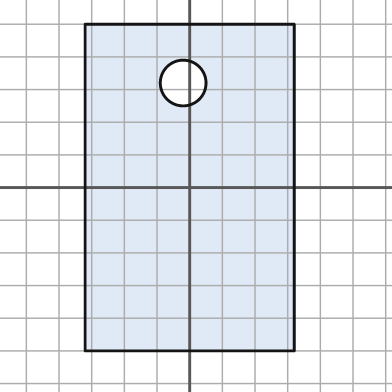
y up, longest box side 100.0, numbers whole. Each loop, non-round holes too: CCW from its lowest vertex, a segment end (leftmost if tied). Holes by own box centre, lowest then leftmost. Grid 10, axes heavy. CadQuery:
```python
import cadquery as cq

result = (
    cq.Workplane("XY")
    .moveTo(-32.0, -50.0)
    .lineTo(32.0, -50.0)
    .lineTo(32.0, 50.0)
    .lineTo(-32.0, 50.0)
    .close()
    .moveTo(-2.0, 32.0)
    .circle(7.0)
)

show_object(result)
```